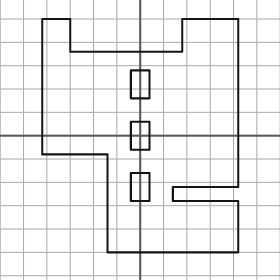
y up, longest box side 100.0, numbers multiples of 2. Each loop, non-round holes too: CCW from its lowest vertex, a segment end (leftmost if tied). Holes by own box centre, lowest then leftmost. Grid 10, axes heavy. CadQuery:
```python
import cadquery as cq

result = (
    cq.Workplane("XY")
    .moveTo(-14.0, -50.0)
    .lineTo(42.0, -50.0)
    .lineTo(42.0, -28.0)
    .lineTo(14.0, -28.0)
    .lineTo(14.0, -22.0)
    .lineTo(42.0, -22.0)
    .lineTo(42.0, 50.0)
    .lineTo(18.0, 50.0)
    .lineTo(18.0, 36.0)
    .lineTo(-30.0, 36.0)
    .lineTo(-30.0, 50.0)
    .lineTo(-42.0, 50.0)
    .lineTo(-42.0, -8.0)
    .lineTo(-14.0, -8.0)
    .close()
    .moveTo(-4.0, -28.0)
    .lineTo(4.0, -28.0)
    .lineTo(4.0, -16.0)
    .lineTo(-4.0, -16.0)
    .close()
    .moveTo(-4.0, -6.0)
    .lineTo(4.0, -6.0)
    .lineTo(4.0, 6.0)
    .lineTo(-4.0, 6.0)
    .close()
    .moveTo(-4.0, 16.0)
    .lineTo(4.0, 16.0)
    .lineTo(4.0, 28.0)
    .lineTo(-4.0, 28.0)
    .close()
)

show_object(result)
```